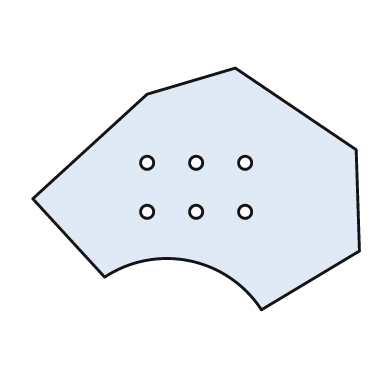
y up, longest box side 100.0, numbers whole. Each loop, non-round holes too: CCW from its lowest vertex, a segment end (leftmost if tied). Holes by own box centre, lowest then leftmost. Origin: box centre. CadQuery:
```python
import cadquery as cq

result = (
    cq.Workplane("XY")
    .moveTo(20.0, -37.0)
    .lineTo(50.0, -19.0)
    .lineTo(49.0, 12.0)
    .lineTo(12.0, 37.0)
    .lineTo(-15.0, 29.0)
    .lineTo(-50.0, -3.0)
    .lineTo(-28.0, -27.0)
    .threePointArc((-2.0, -22.0), (20.0, -37.0))
    .close()
    .moveTo(-15.0, -7.0)
    .circle(2.0)
    .moveTo(0.0, -7.0)
    .circle(2.0)
    .moveTo(15.0, -7.0)
    .circle(2.0)
    .moveTo(-15.0, 8.0)
    .circle(2.0)
    .moveTo(0.0, 8.0)
    .circle(2.0)
    .moveTo(15.0, 8.0)
    .circle(2.0)
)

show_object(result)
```